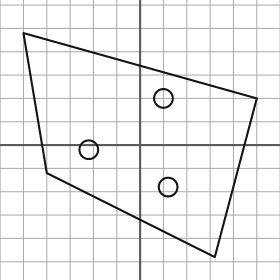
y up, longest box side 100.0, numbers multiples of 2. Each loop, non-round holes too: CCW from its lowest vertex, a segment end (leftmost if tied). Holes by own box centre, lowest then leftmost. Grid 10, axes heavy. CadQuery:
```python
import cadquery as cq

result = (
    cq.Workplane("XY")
    .moveTo(32.0, -48.0)
    .lineTo(50.0, 20.0)
    .lineTo(-50.0, 48.0)
    .lineTo(-40.0, -12.0)
    .close()
    .moveTo(12.0, -18.0)
    .circle(4.0)
    .moveTo(-22.0, -2.0)
    .circle(4.0)
    .moveTo(10.0, 20.0)
    .circle(4.0)
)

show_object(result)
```